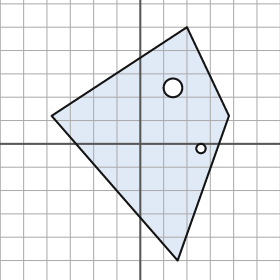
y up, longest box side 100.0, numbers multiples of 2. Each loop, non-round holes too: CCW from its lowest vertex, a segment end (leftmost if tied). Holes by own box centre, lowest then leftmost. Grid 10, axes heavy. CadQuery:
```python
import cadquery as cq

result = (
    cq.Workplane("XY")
    .moveTo(16.0, -50.0)
    .lineTo(38.0, 12.0)
    .lineTo(20.0, 50.0)
    .lineTo(-38.0, 12.0)
    .close()
    .moveTo(26.0, -2.0)
    .circle(2.0)
    .moveTo(14.0, 24.0)
    .circle(4.0)
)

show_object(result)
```